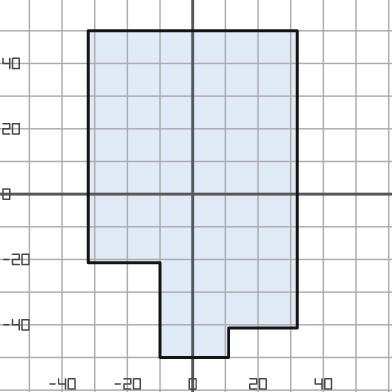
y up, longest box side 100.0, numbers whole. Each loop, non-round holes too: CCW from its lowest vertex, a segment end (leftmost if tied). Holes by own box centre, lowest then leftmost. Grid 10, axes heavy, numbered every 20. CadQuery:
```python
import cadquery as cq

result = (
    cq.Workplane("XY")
    .moveTo(-10.0, -50.0)
    .lineTo(11.0, -50.0)
    .lineTo(11.0, -41.0)
    .lineTo(32.0, -41.0)
    .lineTo(32.0, 50.0)
    .lineTo(-32.0, 50.0)
    .lineTo(-32.0, -21.0)
    .lineTo(-10.0, -21.0)
    .close()
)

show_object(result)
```